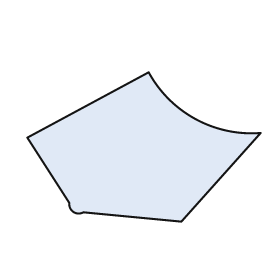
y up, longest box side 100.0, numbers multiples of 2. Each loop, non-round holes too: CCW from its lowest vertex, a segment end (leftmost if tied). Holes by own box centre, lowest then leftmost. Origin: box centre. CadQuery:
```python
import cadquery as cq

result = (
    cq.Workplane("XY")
    .moveTo(16.0, -32.0)
    .lineTo(50.0, 6.0)
    .threePointArc((22.0, 12.0), (2.0, 32.0))
    .lineTo(-50.0, 4.0)
    .lineTo(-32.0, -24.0)
    .threePointArc((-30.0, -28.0), (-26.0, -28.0))
    .close()
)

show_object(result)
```